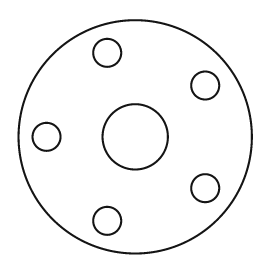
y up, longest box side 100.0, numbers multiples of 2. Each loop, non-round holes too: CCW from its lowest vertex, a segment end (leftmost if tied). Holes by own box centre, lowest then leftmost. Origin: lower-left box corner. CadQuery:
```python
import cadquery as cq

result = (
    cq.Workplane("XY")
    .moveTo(50.0, 50.0)
    .circle(50.0)
    .moveTo(38.0, 14.0)
    .circle(6.0)
    .moveTo(80.0, 28.0)
    .circle(6.0)
    .moveTo(12.0, 50.0)
    .circle(6.0)
    .moveTo(50.0, 50.0)
    .circle(14.0)
    .moveTo(80.0, 72.0)
    .circle(6.0)
    .moveTo(38.0, 86.0)
    .circle(6.0)
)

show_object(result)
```